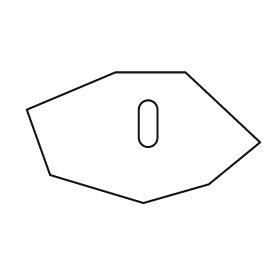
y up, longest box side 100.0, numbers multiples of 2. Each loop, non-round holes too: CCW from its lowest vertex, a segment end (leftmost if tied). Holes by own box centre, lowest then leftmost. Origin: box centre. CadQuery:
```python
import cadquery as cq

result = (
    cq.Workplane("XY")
    .moveTo(0.0, -28.0)
    .lineTo(28.0, -20.0)
    .lineTo(50.0, -2.0)
    .lineTo(18.0, 28.0)
    .lineTo(-12.0, 28.0)
    .lineTo(-50.0, 12.0)
    .lineTo(-40.0, -16.0)
    .close()
    .moveTo(-2.0, 0.0)
    .threePointArc((2.0, -4.0), (6.0, 0.0))
    .lineTo(6.0, 12.0)
    .threePointArc((2.0, 16.0), (-2.0, 12.0))
    .close()
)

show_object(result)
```